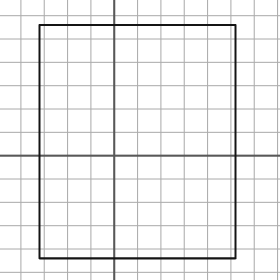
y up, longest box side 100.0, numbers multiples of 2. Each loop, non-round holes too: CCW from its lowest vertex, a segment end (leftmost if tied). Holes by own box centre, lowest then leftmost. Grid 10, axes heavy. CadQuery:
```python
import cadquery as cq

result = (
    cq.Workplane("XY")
    .moveTo(-32.0, -44.0)
    .lineTo(52.0, -44.0)
    .lineTo(52.0, 56.0)
    .lineTo(-32.0, 56.0)
    .close()
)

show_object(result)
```